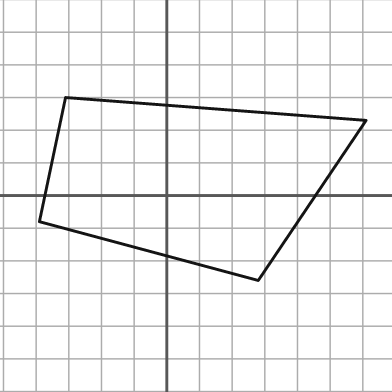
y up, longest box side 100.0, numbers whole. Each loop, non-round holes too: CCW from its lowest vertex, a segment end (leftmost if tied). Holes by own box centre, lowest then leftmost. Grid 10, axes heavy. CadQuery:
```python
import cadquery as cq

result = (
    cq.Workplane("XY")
    .moveTo(28.0, -26.0)
    .lineTo(61.0, 23.0)
    .lineTo(-31.0, 30.0)
    .lineTo(-39.0, -8.0)
    .close()
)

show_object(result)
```